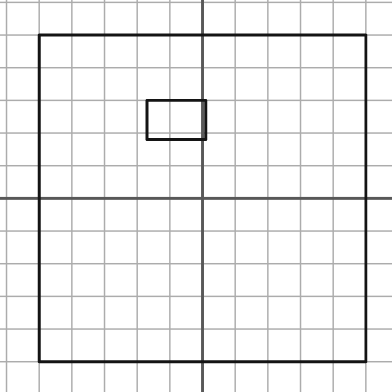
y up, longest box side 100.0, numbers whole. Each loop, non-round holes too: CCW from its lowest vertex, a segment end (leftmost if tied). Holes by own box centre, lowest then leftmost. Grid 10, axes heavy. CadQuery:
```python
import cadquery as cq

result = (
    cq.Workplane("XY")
    .moveTo(-50.0, -50.0)
    .lineTo(50.0, -50.0)
    .lineTo(50.0, 50.0)
    .lineTo(-50.0, 50.0)
    .close()
    .moveTo(-17.0, 18.0)
    .lineTo(1.0, 18.0)
    .lineTo(1.0, 30.0)
    .lineTo(-17.0, 30.0)
    .close()
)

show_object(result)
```